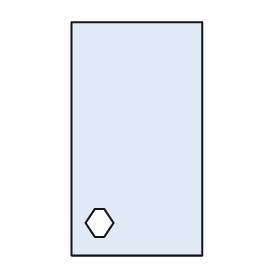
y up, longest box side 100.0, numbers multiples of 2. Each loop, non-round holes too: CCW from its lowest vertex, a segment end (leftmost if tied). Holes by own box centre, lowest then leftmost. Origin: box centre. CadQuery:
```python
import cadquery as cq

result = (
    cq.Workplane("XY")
    .moveTo(-28.0, -50.0)
    .lineTo(28.0, -50.0)
    .lineTo(28.0, 50.0)
    .lineTo(-28.0, 50.0)
    .close()
    .moveTo(-18.0, -42.0)
    .lineTo(-14.0, -42.0)
    .lineTo(-10.0, -36.0)
    .lineTo(-14.0, -30.0)
    .lineTo(-18.0, -30.0)
    .lineTo(-22.0, -36.0)
    .close()
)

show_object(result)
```